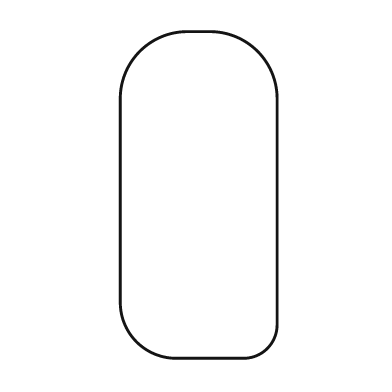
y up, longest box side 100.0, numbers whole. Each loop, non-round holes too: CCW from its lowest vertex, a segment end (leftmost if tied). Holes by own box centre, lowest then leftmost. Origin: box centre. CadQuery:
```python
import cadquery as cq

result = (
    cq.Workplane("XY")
    .moveTo(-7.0, -50.0)
    .lineTo(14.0, -50.0)
    .threePointArc((21.0, -47.0), (24.0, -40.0))
    .lineTo(24.0, 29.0)
    .threePointArc((18.0, 44.0), (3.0, 50.0))
    .lineTo(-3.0, 50.0)
    .threePointArc((-18.0, 44.0), (-24.0, 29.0))
    .lineTo(-24.0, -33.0)
    .threePointArc((-19.0, -45.0), (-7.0, -50.0))
    .close()
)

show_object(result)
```